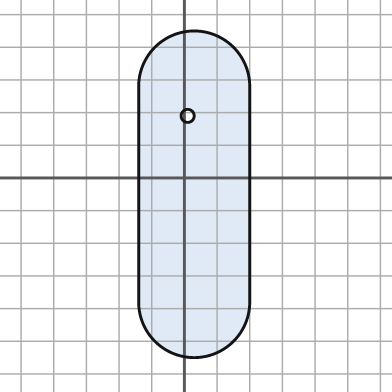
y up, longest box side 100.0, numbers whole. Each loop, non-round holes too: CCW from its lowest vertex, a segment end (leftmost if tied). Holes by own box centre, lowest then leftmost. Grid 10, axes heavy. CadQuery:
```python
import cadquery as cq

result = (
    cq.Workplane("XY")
    .moveTo(-14.0, -38.0)
    .threePointArc((3.0, -55.0), (20.0, -38.0))
    .lineTo(20.0, 28.0)
    .threePointArc((3.0, 45.0), (-14.0, 28.0))
    .close()
    .moveTo(1.0, 19.0)
    .circle(2.0)
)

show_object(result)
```